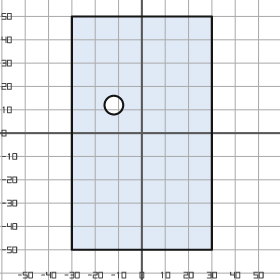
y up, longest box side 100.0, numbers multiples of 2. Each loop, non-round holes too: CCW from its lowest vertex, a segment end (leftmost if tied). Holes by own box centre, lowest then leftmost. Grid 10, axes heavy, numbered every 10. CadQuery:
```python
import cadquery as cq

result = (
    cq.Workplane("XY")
    .moveTo(-30.0, -50.0)
    .lineTo(30.0, -50.0)
    .lineTo(30.0, 50.0)
    .lineTo(-30.0, 50.0)
    .close()
    .moveTo(-12.0, 12.0)
    .circle(4.0)
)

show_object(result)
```